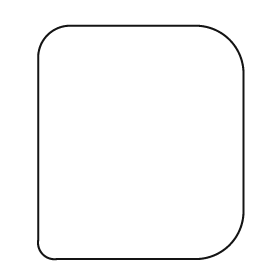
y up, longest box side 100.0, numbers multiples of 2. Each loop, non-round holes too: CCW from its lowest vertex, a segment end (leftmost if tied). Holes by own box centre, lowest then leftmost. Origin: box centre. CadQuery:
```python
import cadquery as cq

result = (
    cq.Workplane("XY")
    .moveTo(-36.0, -50.0)
    .lineTo(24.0, -50.0)
    .threePointArc((38.0, -44.0), (44.0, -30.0))
    .lineTo(44.0, 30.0)
    .threePointArc((38.0, 44.0), (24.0, 50.0))
    .lineTo(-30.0, 50.0)
    .threePointArc((-40.0, 46.0), (-44.0, 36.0))
    .lineTo(-44.0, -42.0)
    .threePointArc((-42.0, -48.0), (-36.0, -50.0))
    .close()
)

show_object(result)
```